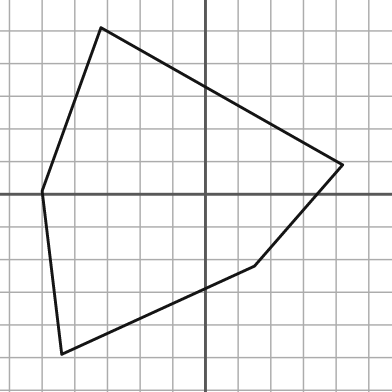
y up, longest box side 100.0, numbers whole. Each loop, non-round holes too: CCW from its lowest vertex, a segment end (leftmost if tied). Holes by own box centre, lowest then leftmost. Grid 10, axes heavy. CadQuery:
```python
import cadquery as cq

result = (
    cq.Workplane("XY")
    .moveTo(-44.0, -49.0)
    .lineTo(15.0, -22.0)
    .lineTo(42.0, 9.0)
    .lineTo(-32.0, 51.0)
    .lineTo(-50.0, 1.0)
    .close()
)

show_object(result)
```